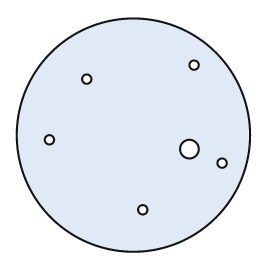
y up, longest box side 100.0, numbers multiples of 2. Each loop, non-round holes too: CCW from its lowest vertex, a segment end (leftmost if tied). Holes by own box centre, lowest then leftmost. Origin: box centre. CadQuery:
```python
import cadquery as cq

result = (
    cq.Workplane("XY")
    .moveTo(0.0, 0.0)
    .circle(50.0)
    .moveTo(4.0, -32.0)
    .circle(2.0)
    .moveTo(38.0, -12.0)
    .circle(2.0)
    .moveTo(24.0, -6.0)
    .circle(4.0)
    .moveTo(-36.0, -2.0)
    .circle(2.0)
    .moveTo(-20.0, 24.0)
    .circle(2.0)
    .moveTo(26.0, 30.0)
    .circle(2.0)
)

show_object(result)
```